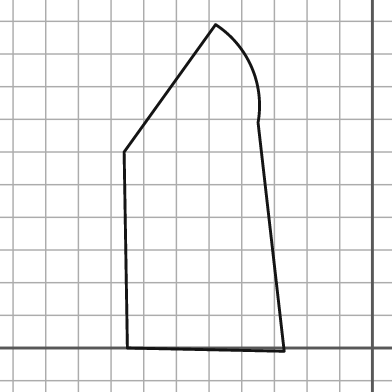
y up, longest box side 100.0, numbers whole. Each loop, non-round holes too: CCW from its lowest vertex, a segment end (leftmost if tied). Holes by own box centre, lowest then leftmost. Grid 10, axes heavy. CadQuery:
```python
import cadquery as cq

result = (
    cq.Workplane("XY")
    .moveTo(-27.0, -1.0)
    .lineTo(-35.0, 69.0)
    .threePointArc((-37.0, 86.0), (-48.0, 99.0))
    .lineTo(-76.0, 60.0)
    .lineTo(-75.0, 0.0)
    .close()
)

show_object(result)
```